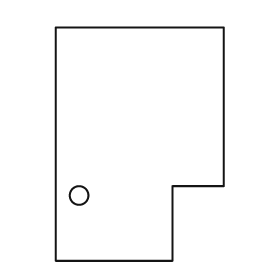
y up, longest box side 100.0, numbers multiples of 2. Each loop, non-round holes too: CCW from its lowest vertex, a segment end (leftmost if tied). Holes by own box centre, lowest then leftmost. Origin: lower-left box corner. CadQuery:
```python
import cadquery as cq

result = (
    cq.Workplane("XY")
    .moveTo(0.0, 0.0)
    .lineTo(50.0, 0.0)
    .lineTo(50.0, 32.0)
    .lineTo(72.0, 32.0)
    .lineTo(72.0, 100.0)
    .lineTo(0.0, 100.0)
    .close()
    .moveTo(10.0, 28.0)
    .circle(4.0)
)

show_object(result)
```